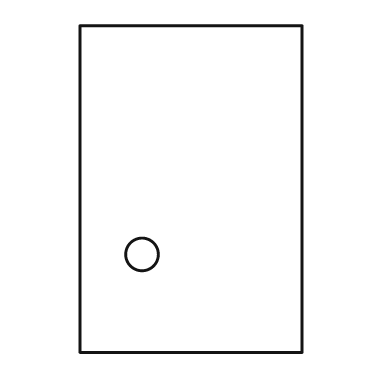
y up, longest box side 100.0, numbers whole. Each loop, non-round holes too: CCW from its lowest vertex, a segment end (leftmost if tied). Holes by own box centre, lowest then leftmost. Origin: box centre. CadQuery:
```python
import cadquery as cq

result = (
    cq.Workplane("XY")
    .moveTo(-34.0, -50.0)
    .lineTo(34.0, -50.0)
    .lineTo(34.0, 50.0)
    .lineTo(-34.0, 50.0)
    .close()
    .moveTo(-15.0, -20.0)
    .circle(5.0)
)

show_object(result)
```